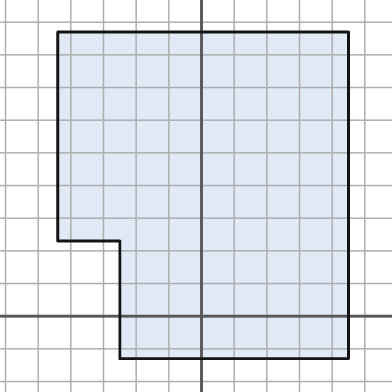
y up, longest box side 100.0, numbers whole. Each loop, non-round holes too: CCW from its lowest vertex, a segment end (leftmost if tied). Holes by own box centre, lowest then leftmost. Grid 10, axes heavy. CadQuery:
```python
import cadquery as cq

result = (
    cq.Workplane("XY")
    .moveTo(-25.0, -13.0)
    .lineTo(45.0, -13.0)
    .lineTo(45.0, 87.0)
    .lineTo(-44.0, 87.0)
    .lineTo(-44.0, 23.0)
    .lineTo(-25.0, 23.0)
    .close()
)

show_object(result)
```